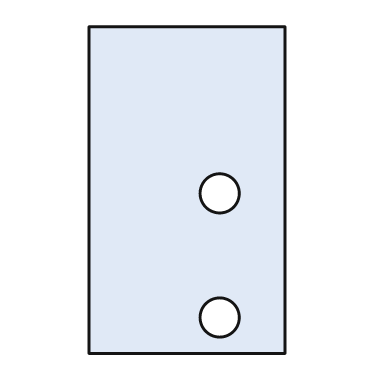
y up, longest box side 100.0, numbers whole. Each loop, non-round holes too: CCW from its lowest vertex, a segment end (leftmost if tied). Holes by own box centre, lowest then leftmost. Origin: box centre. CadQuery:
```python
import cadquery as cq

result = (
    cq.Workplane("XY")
    .moveTo(-30.0, -50.0)
    .lineTo(30.0, -50.0)
    .lineTo(30.0, 50.0)
    .lineTo(-30.0, 50.0)
    .close()
    .moveTo(10.0, -39.0)
    .circle(6.0)
    .moveTo(10.0, -1.0)
    .circle(6.0)
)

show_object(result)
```